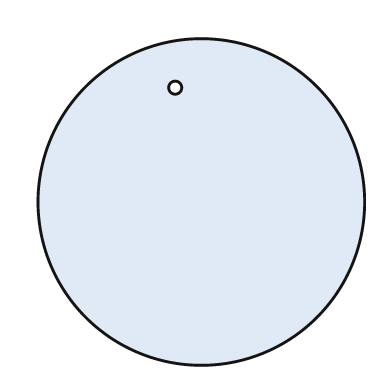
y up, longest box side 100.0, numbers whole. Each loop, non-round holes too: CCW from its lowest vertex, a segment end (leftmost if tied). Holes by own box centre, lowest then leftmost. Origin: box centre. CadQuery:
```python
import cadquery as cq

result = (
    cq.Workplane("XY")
    .moveTo(0.0, 0.0)
    .circle(50.0)
    .moveTo(-8.0, 35.0)
    .circle(2.0)
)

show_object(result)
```